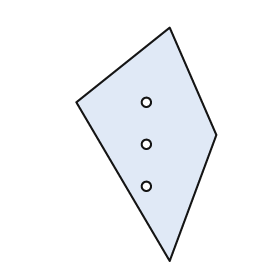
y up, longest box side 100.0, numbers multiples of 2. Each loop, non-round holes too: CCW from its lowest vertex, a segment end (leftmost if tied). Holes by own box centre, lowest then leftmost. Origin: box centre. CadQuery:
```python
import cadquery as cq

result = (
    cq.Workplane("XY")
    .moveTo(10.0, -50.0)
    .lineTo(30.0, 4.0)
    .lineTo(10.0, 50.0)
    .lineTo(-30.0, 18.0)
    .close()
    .moveTo(0.0, -18.0)
    .circle(2.0)
    .moveTo(0.0, 0.0)
    .circle(2.0)
    .moveTo(0.0, 18.0)
    .circle(2.0)
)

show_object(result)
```